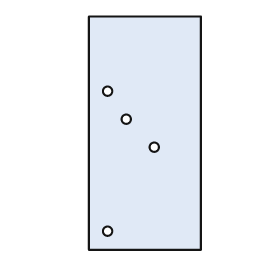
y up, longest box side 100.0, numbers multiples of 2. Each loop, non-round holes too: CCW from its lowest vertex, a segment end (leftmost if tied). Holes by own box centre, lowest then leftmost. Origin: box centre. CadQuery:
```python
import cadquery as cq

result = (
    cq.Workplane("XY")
    .moveTo(-24.0, -50.0)
    .lineTo(24.0, -50.0)
    .lineTo(24.0, 50.0)
    .lineTo(-24.0, 50.0)
    .close()
    .moveTo(-16.0, -42.0)
    .circle(2.0)
    .moveTo(4.0, -6.0)
    .circle(2.0)
    .moveTo(-8.0, 6.0)
    .circle(2.0)
    .moveTo(-16.0, 18.0)
    .circle(2.0)
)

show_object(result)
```